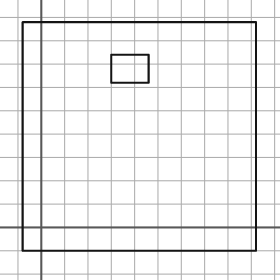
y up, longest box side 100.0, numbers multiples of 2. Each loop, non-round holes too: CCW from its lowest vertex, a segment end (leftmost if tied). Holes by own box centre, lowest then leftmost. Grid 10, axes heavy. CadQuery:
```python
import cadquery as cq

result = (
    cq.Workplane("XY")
    .moveTo(-8.0, -10.0)
    .lineTo(92.0, -10.0)
    .lineTo(92.0, 88.0)
    .lineTo(-8.0, 88.0)
    .close()
    .moveTo(30.0, 62.0)
    .lineTo(46.0, 62.0)
    .lineTo(46.0, 74.0)
    .lineTo(30.0, 74.0)
    .close()
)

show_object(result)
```